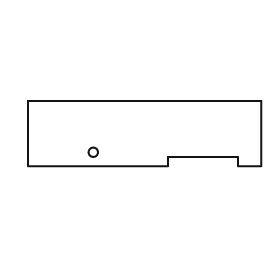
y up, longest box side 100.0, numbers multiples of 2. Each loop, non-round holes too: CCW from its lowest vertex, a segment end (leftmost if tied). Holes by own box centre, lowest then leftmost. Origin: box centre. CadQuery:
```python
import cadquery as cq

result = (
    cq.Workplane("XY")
    .moveTo(-50.0, -14.0)
    .lineTo(10.0, -14.0)
    .lineTo(10.0, -10.0)
    .lineTo(40.0, -10.0)
    .lineTo(40.0, -14.0)
    .lineTo(50.0, -14.0)
    .lineTo(50.0, 14.0)
    .lineTo(-50.0, 14.0)
    .close()
    .moveTo(-22.0, -8.0)
    .circle(2.0)
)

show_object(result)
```